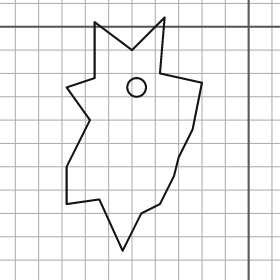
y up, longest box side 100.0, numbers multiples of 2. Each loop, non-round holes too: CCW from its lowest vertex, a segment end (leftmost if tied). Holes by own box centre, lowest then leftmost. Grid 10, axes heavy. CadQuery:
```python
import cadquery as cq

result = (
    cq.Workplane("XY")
    .moveTo(-54.0, -96.0)
    .lineTo(-46.0, -80.0)
    .lineTo(-38.0, -76.0)
    .lineTo(-32.0, -64.0)
    .lineTo(-30.0, -56.0)
    .lineTo(-24.0, -44.0)
    .lineTo(-20.0, -24.0)
    .lineTo(-38.0, -20.0)
    .lineTo(-36.0, 4.0)
    .lineTo(-50.0, -10.0)
    .lineTo(-66.0, 2.0)
    .lineTo(-66.0, -22.0)
    .lineTo(-78.0, -26.0)
    .lineTo(-68.0, -40.0)
    .lineTo(-78.0, -60.0)
    .lineTo(-78.0, -76.0)
    .lineTo(-64.0, -74.0)
    .close()
    .moveTo(-48.0, -26.0)
    .circle(4.0)
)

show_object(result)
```